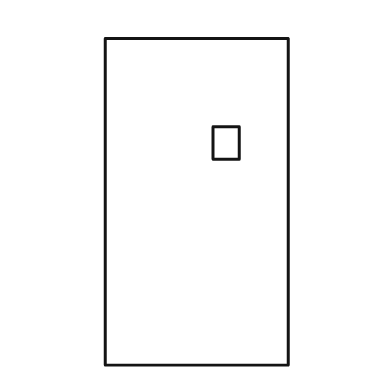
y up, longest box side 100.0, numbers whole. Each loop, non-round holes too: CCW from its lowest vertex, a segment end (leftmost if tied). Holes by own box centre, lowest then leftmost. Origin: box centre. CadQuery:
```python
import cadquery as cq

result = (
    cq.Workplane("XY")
    .moveTo(-28.0, -50.0)
    .lineTo(28.0, -50.0)
    .lineTo(28.0, 50.0)
    .lineTo(-28.0, 50.0)
    .close()
    .moveTo(5.0, 13.0)
    .lineTo(13.0, 13.0)
    .lineTo(13.0, 23.0)
    .lineTo(5.0, 23.0)
    .close()
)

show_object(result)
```